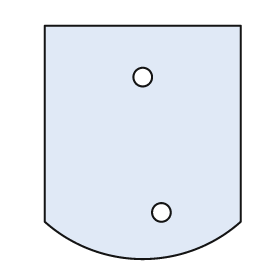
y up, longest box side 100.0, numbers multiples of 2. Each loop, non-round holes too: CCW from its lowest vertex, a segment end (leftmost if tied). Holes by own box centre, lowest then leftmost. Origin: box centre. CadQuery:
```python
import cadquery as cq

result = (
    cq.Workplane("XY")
    .moveTo(-42.0, -34.0)
    .threePointArc((0.0, -50.0), (42.0, -34.0))
    .lineTo(42.0, 50.0)
    .lineTo(-42.0, 50.0)
    .close()
    .moveTo(8.0, -30.0)
    .circle(4.0)
    .moveTo(0.0, 28.0)
    .circle(4.0)
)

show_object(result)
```